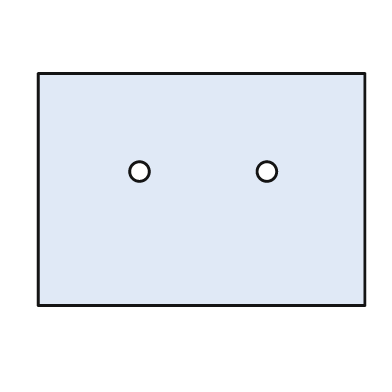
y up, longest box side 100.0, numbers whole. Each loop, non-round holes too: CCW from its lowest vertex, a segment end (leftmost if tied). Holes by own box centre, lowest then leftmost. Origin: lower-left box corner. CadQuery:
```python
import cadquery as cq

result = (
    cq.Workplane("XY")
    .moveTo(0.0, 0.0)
    .lineTo(100.0, 0.0)
    .lineTo(100.0, 71.0)
    .lineTo(0.0, 71.0)
    .close()
    .moveTo(31.0, 41.0)
    .circle(3.0)
    .moveTo(70.0, 41.0)
    .circle(3.0)
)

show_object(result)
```